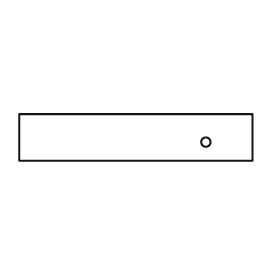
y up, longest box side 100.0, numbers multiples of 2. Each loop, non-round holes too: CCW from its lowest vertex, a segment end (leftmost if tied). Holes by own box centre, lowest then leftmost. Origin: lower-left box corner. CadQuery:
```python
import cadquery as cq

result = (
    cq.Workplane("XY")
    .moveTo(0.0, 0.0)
    .lineTo(100.0, 0.0)
    .lineTo(100.0, 20.0)
    .lineTo(0.0, 20.0)
    .close()
    .moveTo(80.0, 8.0)
    .circle(2.0)
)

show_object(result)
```